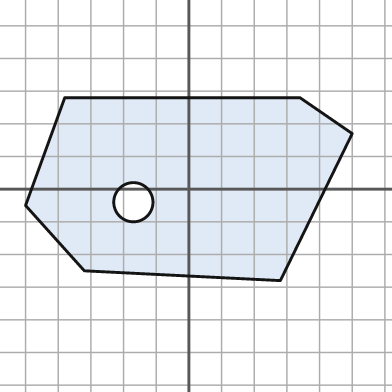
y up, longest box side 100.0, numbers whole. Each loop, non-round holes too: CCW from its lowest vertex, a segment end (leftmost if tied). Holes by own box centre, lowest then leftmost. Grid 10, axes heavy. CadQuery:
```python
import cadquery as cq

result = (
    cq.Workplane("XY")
    .moveTo(28.0, -28.0)
    .lineTo(50.0, 17.0)
    .lineTo(34.0, 28.0)
    .lineTo(-38.0, 28.0)
    .lineTo(-50.0, -5.0)
    .lineTo(-32.0, -25.0)
    .close()
    .moveTo(-17.0, -4.0)
    .circle(6.0)
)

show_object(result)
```